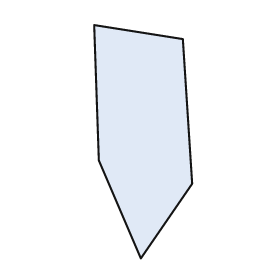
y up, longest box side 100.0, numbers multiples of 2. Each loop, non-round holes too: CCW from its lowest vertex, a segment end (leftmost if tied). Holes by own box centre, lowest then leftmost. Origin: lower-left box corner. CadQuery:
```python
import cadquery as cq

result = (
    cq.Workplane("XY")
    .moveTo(20.0, 0.0)
    .lineTo(42.0, 32.0)
    .lineTo(38.0, 94.0)
    .lineTo(0.0, 100.0)
    .lineTo(2.0, 42.0)
    .close()
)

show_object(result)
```